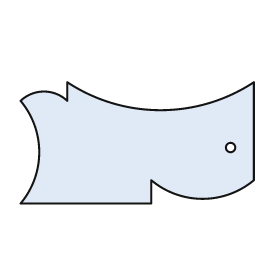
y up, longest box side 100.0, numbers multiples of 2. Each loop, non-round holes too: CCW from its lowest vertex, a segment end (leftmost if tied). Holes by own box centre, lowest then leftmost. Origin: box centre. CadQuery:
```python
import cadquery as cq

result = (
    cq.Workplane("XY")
    .moveTo(-50.0, -26.0)
    .lineTo(6.0, -26.0)
    .lineTo(6.0, -16.0)
    .threePointArc((28.0, -24.0), (50.0, -16.0))
    .lineTo(50.0, 26.0)
    .threePointArc((10.0, 14.0), (-30.0, 26.0))
    .lineTo(-30.0, 18.0)
    .threePointArc((-40.0, 22.0), (-50.0, 18.0))
    .threePointArc((-42.0, -4.0), (-50.0, -26.0))
    .close()
    .moveTo(40.0, -2.0)
    .circle(2.0)
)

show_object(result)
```